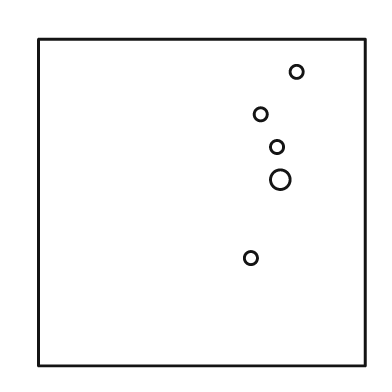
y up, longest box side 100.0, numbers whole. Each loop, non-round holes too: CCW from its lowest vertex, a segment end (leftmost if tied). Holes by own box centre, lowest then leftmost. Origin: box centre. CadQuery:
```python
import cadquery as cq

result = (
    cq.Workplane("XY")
    .moveTo(-50.0, -50.0)
    .lineTo(50.0, -50.0)
    .lineTo(50.0, 50.0)
    .lineTo(-50.0, 50.0)
    .close()
    .moveTo(15.0, -17.0)
    .circle(2.0)
    .moveTo(24.0, 7.0)
    .circle(3.0)
    .moveTo(23.0, 17.0)
    .circle(2.0)
    .moveTo(18.0, 27.0)
    .circle(2.0)
    .moveTo(29.0, 40.0)
    .circle(2.0)
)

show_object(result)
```